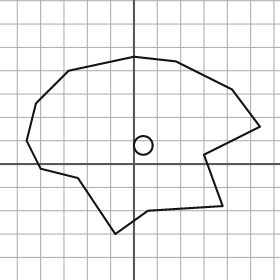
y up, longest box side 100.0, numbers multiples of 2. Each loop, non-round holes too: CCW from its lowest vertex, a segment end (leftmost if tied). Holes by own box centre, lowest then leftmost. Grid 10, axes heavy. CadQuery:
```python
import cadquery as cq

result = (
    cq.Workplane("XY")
    .moveTo(-8.0, -30.0)
    .lineTo(6.0, -20.0)
    .lineTo(38.0, -18.0)
    .lineTo(30.0, 4.0)
    .lineTo(54.0, 16.0)
    .lineTo(42.0, 32.0)
    .lineTo(18.0, 44.0)
    .lineTo(0.0, 46.0)
    .lineTo(-28.0, 40.0)
    .lineTo(-42.0, 26.0)
    .lineTo(-46.0, 10.0)
    .lineTo(-40.0, -2.0)
    .lineTo(-24.0, -6.0)
    .close()
    .moveTo(4.0, 8.0)
    .circle(4.0)
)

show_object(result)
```